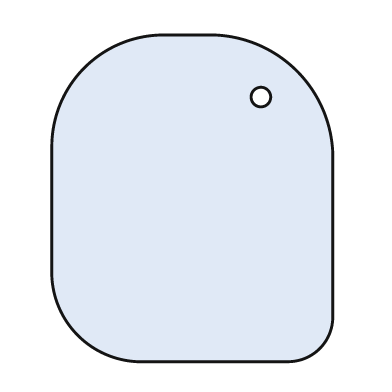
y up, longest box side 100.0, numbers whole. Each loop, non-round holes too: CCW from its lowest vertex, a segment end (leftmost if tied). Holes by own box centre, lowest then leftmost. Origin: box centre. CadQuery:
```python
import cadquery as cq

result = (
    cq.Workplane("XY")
    .moveTo(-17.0, -50.0)
    .lineTo(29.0, -50.0)
    .threePointArc((39.0, -46.0), (43.0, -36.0))
    .lineTo(43.0, 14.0)
    .threePointArc((32.0, 39.0), (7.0, 50.0))
    .lineTo(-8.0, 50.0)
    .threePointArc((-33.0, 40.0), (-43.0, 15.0))
    .lineTo(-43.0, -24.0)
    .threePointArc((-35.0, -42.0), (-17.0, -50.0))
    .close()
    .moveTo(21.0, 31.0)
    .circle(3.0)
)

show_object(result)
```